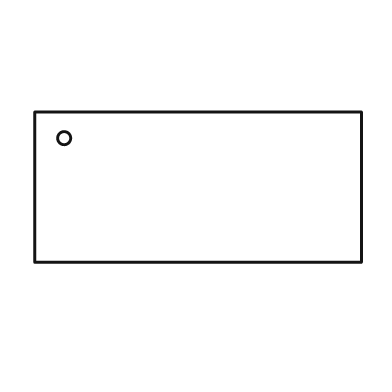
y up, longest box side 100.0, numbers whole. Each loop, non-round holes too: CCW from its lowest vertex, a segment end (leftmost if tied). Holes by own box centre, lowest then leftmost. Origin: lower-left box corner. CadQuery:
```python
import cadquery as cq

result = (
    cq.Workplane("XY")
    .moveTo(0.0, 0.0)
    .lineTo(100.0, 0.0)
    .lineTo(100.0, 46.0)
    .lineTo(0.0, 46.0)
    .close()
    .moveTo(9.0, 38.0)
    .circle(2.0)
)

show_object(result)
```